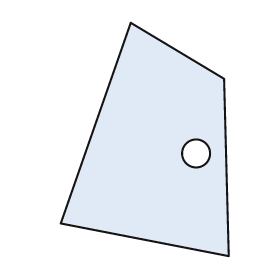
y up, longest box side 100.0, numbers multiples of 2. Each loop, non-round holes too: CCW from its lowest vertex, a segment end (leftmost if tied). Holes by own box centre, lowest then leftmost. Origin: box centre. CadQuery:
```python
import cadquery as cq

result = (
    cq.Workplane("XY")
    .moveTo(36.0, -50.0)
    .lineTo(34.0, 26.0)
    .lineTo(-6.0, 50.0)
    .lineTo(-36.0, -36.0)
    .close()
    .moveTo(22.0, -6.0)
    .circle(6.0)
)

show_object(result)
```